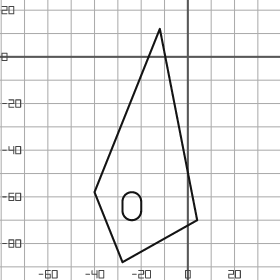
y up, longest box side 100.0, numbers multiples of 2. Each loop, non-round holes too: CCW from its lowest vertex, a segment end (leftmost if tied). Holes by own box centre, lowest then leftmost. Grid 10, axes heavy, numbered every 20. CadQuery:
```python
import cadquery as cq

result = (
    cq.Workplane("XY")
    .moveTo(-28.0, -88.0)
    .lineTo(4.0, -70.0)
    .lineTo(-12.0, 12.0)
    .lineTo(-40.0, -58.0)
    .close()
    .moveTo(-28.0, -66.0)
    .threePointArc((-24.0, -70.0), (-20.0, -66.0))
    .lineTo(-20.0, -62.0)
    .threePointArc((-24.0, -58.0), (-28.0, -62.0))
    .close()
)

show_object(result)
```